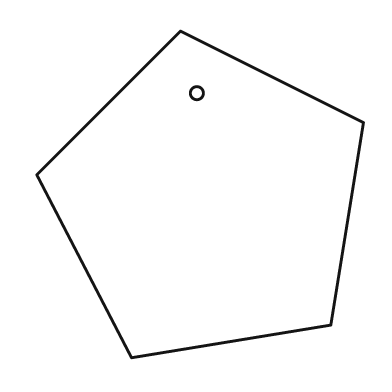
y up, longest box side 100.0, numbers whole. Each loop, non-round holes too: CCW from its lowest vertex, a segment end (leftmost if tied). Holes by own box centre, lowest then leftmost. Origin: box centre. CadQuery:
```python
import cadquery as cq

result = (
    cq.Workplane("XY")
    .moveTo(-21.0, -50.0)
    .lineTo(40.0, -40.0)
    .lineTo(50.0, 22.0)
    .lineTo(-6.0, 50.0)
    .lineTo(-50.0, 6.0)
    .close()
    .moveTo(-1.0, 31.0)
    .circle(2.0)
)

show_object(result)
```